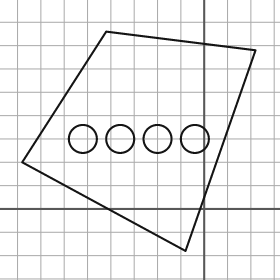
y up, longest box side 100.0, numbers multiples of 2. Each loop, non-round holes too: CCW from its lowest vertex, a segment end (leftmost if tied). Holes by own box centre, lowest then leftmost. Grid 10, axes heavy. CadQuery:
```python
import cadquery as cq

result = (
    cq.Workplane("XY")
    .moveTo(-8.0, -18.0)
    .lineTo(22.0, 68.0)
    .lineTo(-42.0, 76.0)
    .lineTo(-78.0, 20.0)
    .close()
    .moveTo(-52.0, 30.0)
    .circle(6.0)
    .moveTo(-36.0, 30.0)
    .circle(6.0)
    .moveTo(-20.0, 30.0)
    .circle(6.0)
    .moveTo(-4.0, 30.0)
    .circle(6.0)
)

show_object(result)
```